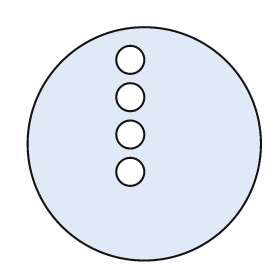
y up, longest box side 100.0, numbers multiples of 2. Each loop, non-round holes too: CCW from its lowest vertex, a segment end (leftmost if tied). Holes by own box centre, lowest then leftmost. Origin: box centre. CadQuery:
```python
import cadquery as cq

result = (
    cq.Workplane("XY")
    .moveTo(0.0, 0.0)
    .circle(50.0)
    .moveTo(-6.0, -12.0)
    .circle(6.0)
    .moveTo(-6.0, 4.0)
    .circle(6.0)
    .moveTo(-6.0, 20.0)
    .circle(6.0)
    .moveTo(-6.0, 36.0)
    .circle(6.0)
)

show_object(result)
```